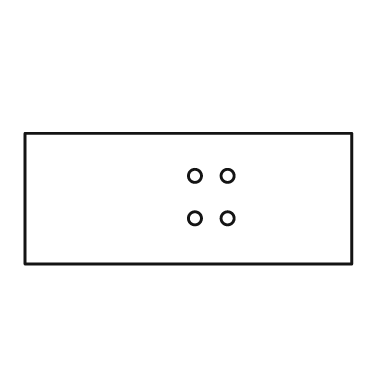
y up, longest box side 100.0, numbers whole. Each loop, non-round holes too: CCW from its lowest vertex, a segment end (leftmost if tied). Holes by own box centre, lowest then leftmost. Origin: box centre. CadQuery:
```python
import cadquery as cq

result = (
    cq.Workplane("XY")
    .moveTo(-50.0, -20.0)
    .lineTo(50.0, -20.0)
    .lineTo(50.0, 20.0)
    .lineTo(-50.0, 20.0)
    .close()
    .moveTo(2.0, -6.0)
    .circle(2.0)
    .moveTo(12.0, -6.0)
    .circle(2.0)
    .moveTo(2.0, 7.0)
    .circle(2.0)
    .moveTo(12.0, 7.0)
    .circle(2.0)
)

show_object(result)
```